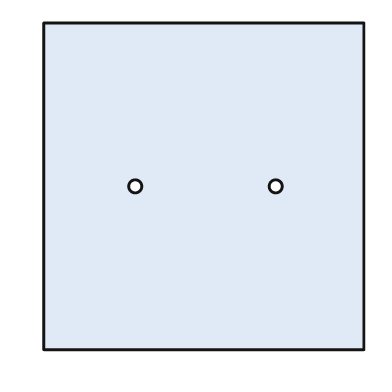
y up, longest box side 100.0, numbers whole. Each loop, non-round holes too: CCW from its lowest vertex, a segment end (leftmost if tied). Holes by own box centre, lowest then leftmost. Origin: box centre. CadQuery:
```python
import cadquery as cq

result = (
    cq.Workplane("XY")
    .moveTo(-49.0, -50.0)
    .lineTo(49.0, -50.0)
    .lineTo(49.0, 50.0)
    .lineTo(-49.0, 50.0)
    .close()
    .moveTo(-21.0, 0.0)
    .circle(2.0)
    .moveTo(22.0, 0.0)
    .circle(2.0)
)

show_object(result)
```